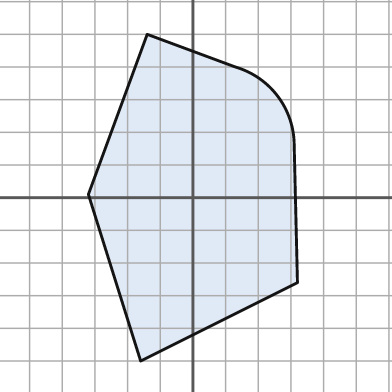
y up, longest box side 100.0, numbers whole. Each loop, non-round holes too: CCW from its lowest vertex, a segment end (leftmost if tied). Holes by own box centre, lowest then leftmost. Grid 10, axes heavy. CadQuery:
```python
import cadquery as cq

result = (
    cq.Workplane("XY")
    .moveTo(-16.0, -50.0)
    .lineTo(32.0, -26.0)
    .lineTo(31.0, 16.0)
    .threePointArc((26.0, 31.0), (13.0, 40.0))
    .lineTo(-14.0, 50.0)
    .lineTo(-32.0, 1.0)
    .close()
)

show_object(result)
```